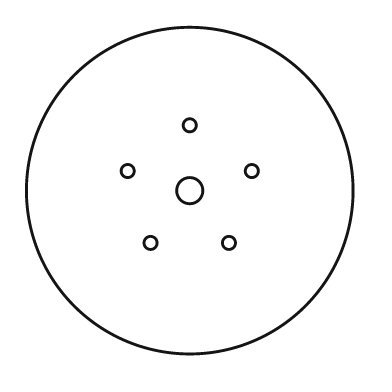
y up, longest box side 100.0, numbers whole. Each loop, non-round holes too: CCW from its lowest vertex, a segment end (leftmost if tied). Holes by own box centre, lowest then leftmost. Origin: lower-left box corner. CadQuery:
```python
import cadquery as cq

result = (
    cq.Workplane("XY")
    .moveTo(50.0, 50.0)
    .circle(50.0)
    .moveTo(38.0, 34.0)
    .circle(2.0)
    .moveTo(62.0, 34.0)
    .circle(2.0)
    .moveTo(50.0, 50.0)
    .circle(4.0)
    .moveTo(31.0, 56.0)
    .circle(2.0)
    .moveTo(69.0, 56.0)
    .circle(2.0)
    .moveTo(50.0, 70.0)
    .circle(2.0)
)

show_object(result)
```